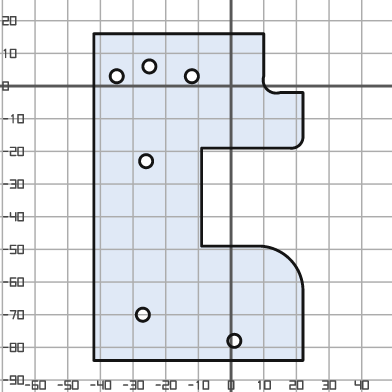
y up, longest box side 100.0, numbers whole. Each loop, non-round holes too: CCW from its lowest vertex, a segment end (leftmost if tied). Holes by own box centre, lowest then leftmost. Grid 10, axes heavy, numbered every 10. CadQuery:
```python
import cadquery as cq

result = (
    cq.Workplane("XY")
    .moveTo(-42.0, -84.0)
    .lineTo(22.0, -84.0)
    .lineTo(22.0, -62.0)
    .threePointArc((18.0, -53.0), (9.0, -49.0))
    .lineTo(-9.0, -49.0)
    .lineTo(-9.0, -19.0)
    .lineTo(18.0, -19.0)
    .threePointArc((21.0, -18.0), (22.0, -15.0))
    .lineTo(22.0, -2.0)
    .lineTo(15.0, -2.0)
    .threePointArc((11.0, -1.0), (10.0, 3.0))
    .lineTo(10.0, 16.0)
    .lineTo(-42.0, 16.0)
    .close()
    .moveTo(1.0, -78.0)
    .circle(2.0)
    .moveTo(-27.0, -70.0)
    .circle(2.0)
    .moveTo(-26.0, -23.0)
    .circle(2.0)
    .moveTo(-35.0, 3.0)
    .circle(2.0)
    .moveTo(-12.0, 3.0)
    .circle(2.0)
    .moveTo(-25.0, 6.0)
    .circle(2.0)
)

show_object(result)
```